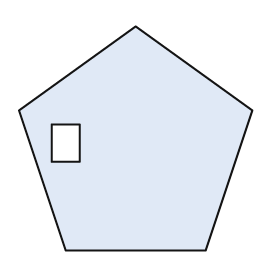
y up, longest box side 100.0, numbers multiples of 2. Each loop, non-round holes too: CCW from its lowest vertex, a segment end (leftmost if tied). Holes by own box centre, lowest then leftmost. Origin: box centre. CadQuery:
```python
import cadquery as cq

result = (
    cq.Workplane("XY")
    .moveTo(-30.0, -48.0)
    .lineTo(30.0, -48.0)
    .lineTo(50.0, 12.0)
    .lineTo(0.0, 48.0)
    .lineTo(-50.0, 12.0)
    .close()
    .moveTo(-36.0, -10.0)
    .lineTo(-24.0, -10.0)
    .lineTo(-24.0, 6.0)
    .lineTo(-36.0, 6.0)
    .close()
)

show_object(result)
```